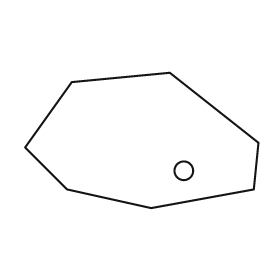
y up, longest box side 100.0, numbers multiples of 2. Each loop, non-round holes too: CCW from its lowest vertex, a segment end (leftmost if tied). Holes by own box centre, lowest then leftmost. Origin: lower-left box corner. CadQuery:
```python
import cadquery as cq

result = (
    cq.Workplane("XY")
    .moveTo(54.0, 0.0)
    .lineTo(98.0, 8.0)
    .lineTo(100.0, 28.0)
    .lineTo(62.0, 58.0)
    .lineTo(20.0, 54.0)
    .lineTo(0.0, 26.0)
    .lineTo(18.0, 8.0)
    .close()
    .moveTo(68.0, 16.0)
    .circle(4.0)
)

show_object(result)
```